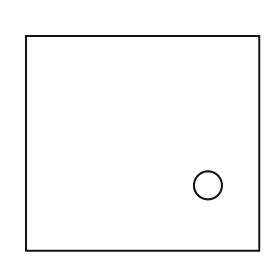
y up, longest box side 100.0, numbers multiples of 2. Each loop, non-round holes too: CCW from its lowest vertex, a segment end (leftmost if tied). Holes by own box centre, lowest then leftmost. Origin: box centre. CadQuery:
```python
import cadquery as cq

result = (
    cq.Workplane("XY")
    .moveTo(-50.0, -46.0)
    .lineTo(50.0, -46.0)
    .lineTo(50.0, 46.0)
    .lineTo(-50.0, 46.0)
    .close()
    .moveTo(28.0, -18.0)
    .circle(6.0)
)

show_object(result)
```